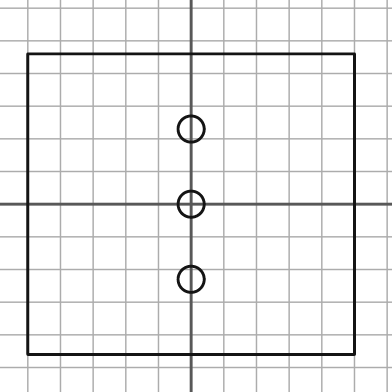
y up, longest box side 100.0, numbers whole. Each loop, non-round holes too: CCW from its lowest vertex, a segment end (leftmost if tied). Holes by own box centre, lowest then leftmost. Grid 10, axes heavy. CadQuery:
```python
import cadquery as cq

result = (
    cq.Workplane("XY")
    .moveTo(-50.0, -46.0)
    .lineTo(50.0, -46.0)
    .lineTo(50.0, 46.0)
    .lineTo(-50.0, 46.0)
    .close()
    .moveTo(0.0, -23.0)
    .circle(4.0)
    .moveTo(0.0, 0.0)
    .circle(4.0)
    .moveTo(0.0, 23.0)
    .circle(4.0)
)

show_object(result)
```